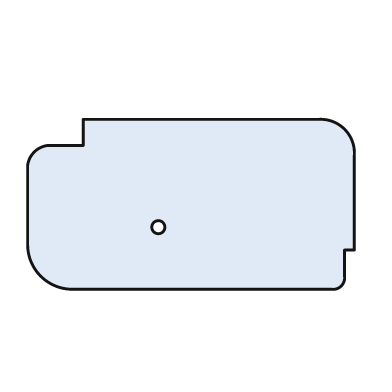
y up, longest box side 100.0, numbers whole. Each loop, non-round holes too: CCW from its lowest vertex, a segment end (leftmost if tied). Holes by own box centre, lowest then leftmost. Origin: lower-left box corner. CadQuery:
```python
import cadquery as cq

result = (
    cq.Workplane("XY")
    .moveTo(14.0, 0.0)
    .lineTo(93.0, 0.0)
    .threePointArc((96.0, 1.0), (97.0, 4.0))
    .lineTo(97.0, 12.0)
    .lineTo(100.0, 12.0)
    .lineTo(100.0, 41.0)
    .threePointArc((97.0, 49.0), (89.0, 52.0))
    .lineTo(17.0, 52.0)
    .lineTo(17.0, 44.0)
    .lineTo(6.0, 44.0)
    .threePointArc((2.0, 42.0), (0.0, 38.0))
    .lineTo(0.0, 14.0)
    .threePointArc((4.0, 4.0), (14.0, 0.0))
    .close()
    .moveTo(40.0, 19.0)
    .circle(2.0)
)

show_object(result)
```